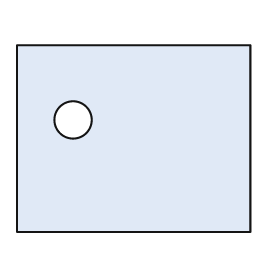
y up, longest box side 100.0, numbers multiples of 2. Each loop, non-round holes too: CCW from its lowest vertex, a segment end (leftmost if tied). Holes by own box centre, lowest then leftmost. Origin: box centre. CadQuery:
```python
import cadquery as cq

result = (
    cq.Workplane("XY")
    .moveTo(-50.0, -40.0)
    .lineTo(50.0, -40.0)
    .lineTo(50.0, 40.0)
    .lineTo(-50.0, 40.0)
    .close()
    .moveTo(-26.0, 8.0)
    .circle(8.0)
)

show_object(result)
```